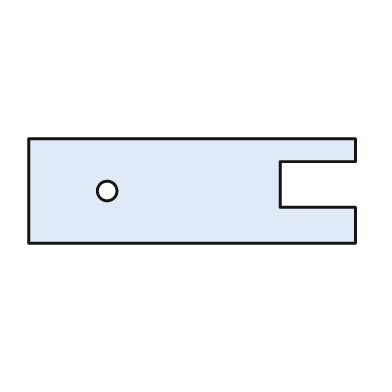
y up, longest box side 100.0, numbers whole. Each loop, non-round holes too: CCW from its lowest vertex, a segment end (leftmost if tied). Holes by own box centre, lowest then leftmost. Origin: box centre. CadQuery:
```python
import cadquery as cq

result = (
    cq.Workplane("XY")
    .moveTo(-50.0, -16.0)
    .lineTo(50.0, -16.0)
    .lineTo(50.0, -5.0)
    .lineTo(27.0, -5.0)
    .lineTo(27.0, 9.0)
    .lineTo(50.0, 9.0)
    .lineTo(50.0, 16.0)
    .lineTo(-50.0, 16.0)
    .close()
    .moveTo(-26.0, 0.0)
    .circle(3.0)
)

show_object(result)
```